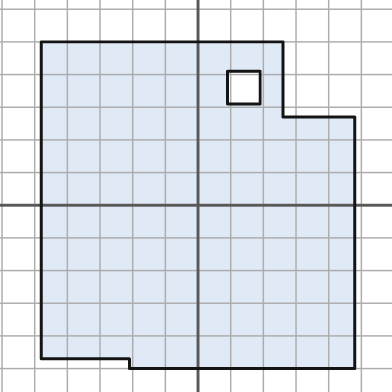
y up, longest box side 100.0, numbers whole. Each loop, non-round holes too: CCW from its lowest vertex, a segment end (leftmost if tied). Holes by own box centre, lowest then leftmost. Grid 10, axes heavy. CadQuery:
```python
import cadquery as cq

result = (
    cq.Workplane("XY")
    .moveTo(-21.0, -50.0)
    .lineTo(48.0, -50.0)
    .lineTo(48.0, 27.0)
    .lineTo(26.0, 27.0)
    .lineTo(26.0, 50.0)
    .lineTo(-48.0, 50.0)
    .lineTo(-48.0, -47.0)
    .lineTo(-21.0, -47.0)
    .close()
    .moveTo(9.0, 31.0)
    .lineTo(19.0, 31.0)
    .lineTo(19.0, 41.0)
    .lineTo(9.0, 41.0)
    .close()
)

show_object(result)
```